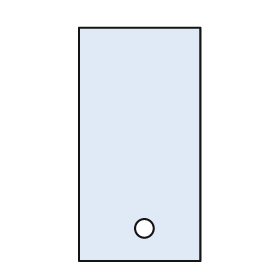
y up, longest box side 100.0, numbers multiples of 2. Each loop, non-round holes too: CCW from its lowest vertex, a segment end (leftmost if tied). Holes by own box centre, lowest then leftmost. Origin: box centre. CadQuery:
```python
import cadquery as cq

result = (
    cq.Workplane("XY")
    .moveTo(-26.0, -50.0)
    .lineTo(26.0, -50.0)
    .lineTo(26.0, 50.0)
    .lineTo(-26.0, 50.0)
    .close()
    .moveTo(2.0, -36.0)
    .circle(4.0)
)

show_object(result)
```